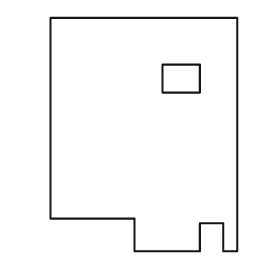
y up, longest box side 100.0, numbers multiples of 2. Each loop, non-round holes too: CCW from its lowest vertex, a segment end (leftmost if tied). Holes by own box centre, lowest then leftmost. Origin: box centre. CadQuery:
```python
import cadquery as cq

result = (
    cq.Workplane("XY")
    .moveTo(-4.0, -50.0)
    .lineTo(24.0, -50.0)
    .lineTo(24.0, -38.0)
    .lineTo(34.0, -38.0)
    .lineTo(34.0, -50.0)
    .lineTo(40.0, -50.0)
    .lineTo(40.0, 50.0)
    .lineTo(-40.0, 50.0)
    .lineTo(-40.0, -36.0)
    .lineTo(-4.0, -36.0)
    .close()
    .moveTo(8.0, 18.0)
    .lineTo(24.0, 18.0)
    .lineTo(24.0, 30.0)
    .lineTo(8.0, 30.0)
    .close()
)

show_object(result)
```